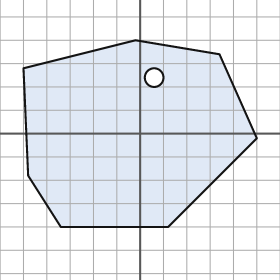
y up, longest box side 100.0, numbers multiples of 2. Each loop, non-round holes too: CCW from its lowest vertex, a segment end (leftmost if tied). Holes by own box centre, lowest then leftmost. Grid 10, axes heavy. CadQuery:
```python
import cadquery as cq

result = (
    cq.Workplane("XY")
    .moveTo(-34.0, -40.0)
    .lineTo(12.0, -40.0)
    .lineTo(50.0, -2.0)
    .lineTo(34.0, 34.0)
    .lineTo(-2.0, 40.0)
    .lineTo(-50.0, 28.0)
    .lineTo(-48.0, -18.0)
    .close()
    .moveTo(6.0, 24.0)
    .circle(4.0)
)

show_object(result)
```